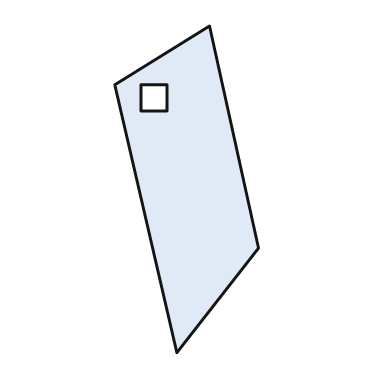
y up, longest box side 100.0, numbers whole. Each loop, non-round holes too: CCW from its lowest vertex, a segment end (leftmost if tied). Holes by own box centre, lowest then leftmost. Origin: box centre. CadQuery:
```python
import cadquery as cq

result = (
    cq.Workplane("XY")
    .moveTo(-3.0, -50.0)
    .lineTo(22.0, -18.0)
    .lineTo(7.0, 50.0)
    .lineTo(-22.0, 32.0)
    .close()
    .moveTo(-14.0, 24.0)
    .lineTo(-6.0, 24.0)
    .lineTo(-6.0, 32.0)
    .lineTo(-14.0, 32.0)
    .close()
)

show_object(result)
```